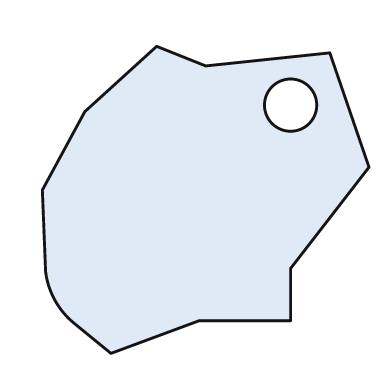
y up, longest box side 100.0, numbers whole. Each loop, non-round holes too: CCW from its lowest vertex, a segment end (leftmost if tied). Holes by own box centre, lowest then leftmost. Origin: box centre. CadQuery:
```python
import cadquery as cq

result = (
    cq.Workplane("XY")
    .moveTo(-29.0, -47.0)
    .lineTo(-2.0, -37.0)
    .lineTo(26.0, -37.0)
    .lineTo(26.0, -21.0)
    .lineTo(50.0, 10.0)
    .lineTo(38.0, 45.0)
    .lineTo(0.0, 41.0)
    .lineTo(-15.0, 47.0)
    .lineTo(-37.0, 27.0)
    .lineTo(-50.0, 3.0)
    .lineTo(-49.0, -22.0)
    .threePointArc((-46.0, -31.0), (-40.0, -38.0))
    .close()
    .moveTo(26.0, 29.0)
    .circle(8.0)
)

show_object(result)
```